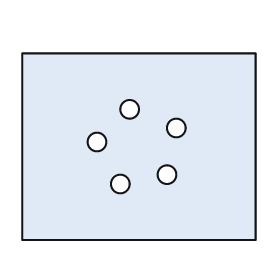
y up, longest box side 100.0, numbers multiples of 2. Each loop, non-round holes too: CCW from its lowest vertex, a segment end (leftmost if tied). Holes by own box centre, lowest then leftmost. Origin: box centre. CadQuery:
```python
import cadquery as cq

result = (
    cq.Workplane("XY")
    .moveTo(-50.0, -40.0)
    .lineTo(50.0, -40.0)
    .lineTo(50.0, 40.0)
    .lineTo(-50.0, 40.0)
    .close()
    .moveTo(-8.0, -16.0)
    .circle(4.0)
    .moveTo(12.0, -12.0)
    .circle(4.0)
    .moveTo(-18.0, 2.0)
    .circle(4.0)
    .moveTo(16.0, 8.0)
    .circle(4.0)
    .moveTo(-4.0, 16.0)
    .circle(4.0)
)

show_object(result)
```